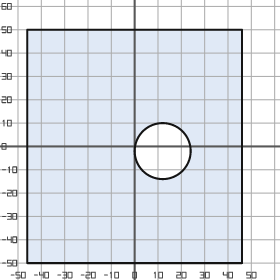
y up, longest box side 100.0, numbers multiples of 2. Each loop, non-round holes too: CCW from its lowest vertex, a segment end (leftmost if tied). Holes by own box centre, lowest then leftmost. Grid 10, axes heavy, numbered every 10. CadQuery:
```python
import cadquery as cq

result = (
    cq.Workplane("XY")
    .moveTo(-46.0, -50.0)
    .lineTo(46.0, -50.0)
    .lineTo(46.0, 50.0)
    .lineTo(-46.0, 50.0)
    .close()
    .moveTo(12.0, -2.0)
    .circle(12.0)
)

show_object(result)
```